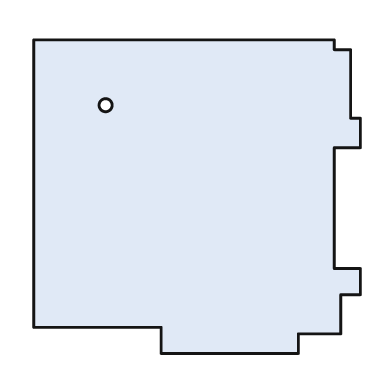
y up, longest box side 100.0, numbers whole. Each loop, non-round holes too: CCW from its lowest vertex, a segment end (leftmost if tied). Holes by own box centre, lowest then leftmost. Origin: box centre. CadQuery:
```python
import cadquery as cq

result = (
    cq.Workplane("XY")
    .moveTo(-11.0, -48.0)
    .lineTo(31.0, -48.0)
    .lineTo(31.0, -42.0)
    .lineTo(44.0, -42.0)
    .lineTo(44.0, -30.0)
    .lineTo(50.0, -30.0)
    .lineTo(50.0, -22.0)
    .lineTo(42.0, -22.0)
    .lineTo(42.0, 15.0)
    .lineTo(50.0, 15.0)
    .lineTo(50.0, 24.0)
    .lineTo(47.0, 24.0)
    .lineTo(47.0, 45.0)
    .lineTo(42.0, 45.0)
    .lineTo(42.0, 48.0)
    .lineTo(-50.0, 48.0)
    .lineTo(-50.0, -40.0)
    .lineTo(-11.0, -40.0)
    .close()
    .moveTo(-28.0, 28.0)
    .circle(2.0)
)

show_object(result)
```